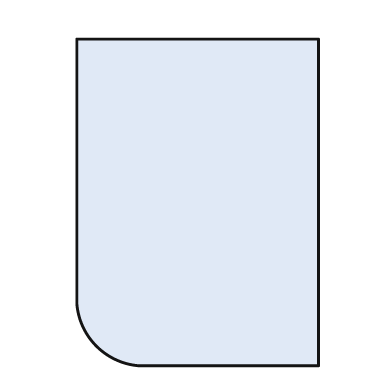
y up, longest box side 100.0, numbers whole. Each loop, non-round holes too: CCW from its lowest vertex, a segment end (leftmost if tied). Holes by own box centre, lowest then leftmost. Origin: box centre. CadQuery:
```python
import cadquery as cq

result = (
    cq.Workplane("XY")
    .moveTo(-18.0, -50.0)
    .lineTo(37.0, -50.0)
    .lineTo(37.0, 50.0)
    .lineTo(-37.0, 50.0)
    .lineTo(-37.0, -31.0)
    .threePointArc((-31.0, -44.0), (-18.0, -50.0))
    .close()
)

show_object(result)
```